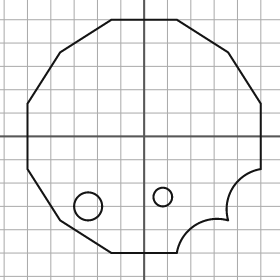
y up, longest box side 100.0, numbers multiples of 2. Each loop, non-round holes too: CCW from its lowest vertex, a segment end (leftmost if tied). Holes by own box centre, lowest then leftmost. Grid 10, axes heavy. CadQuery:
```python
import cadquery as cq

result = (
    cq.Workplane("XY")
    .moveTo(-14.0, -50.0)
    .lineTo(14.0, -50.0)
    .threePointArc((22.0, -38.0), (36.0, -36.0))
    .threePointArc((38.0, -22.0), (50.0, -14.0))
    .lineTo(50.0, 14.0)
    .lineTo(36.0, 36.0)
    .lineTo(14.0, 50.0)
    .lineTo(-14.0, 50.0)
    .lineTo(-36.0, 36.0)
    .lineTo(-50.0, 14.0)
    .lineTo(-50.0, -14.0)
    .lineTo(-36.0, -36.0)
    .close()
    .moveTo(-24.0, -30.0)
    .circle(6.0)
    .moveTo(8.0, -26.0)
    .circle(4.0)
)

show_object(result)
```